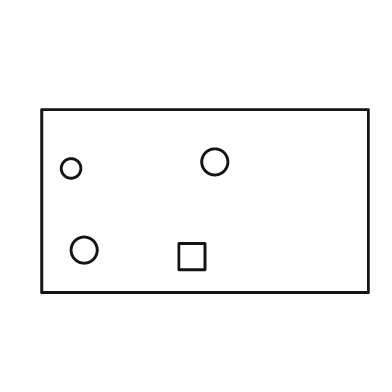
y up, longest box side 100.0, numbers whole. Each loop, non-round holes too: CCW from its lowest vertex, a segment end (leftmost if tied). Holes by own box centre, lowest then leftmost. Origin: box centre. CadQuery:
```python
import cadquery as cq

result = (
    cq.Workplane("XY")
    .moveTo(-50.0, -28.0)
    .lineTo(50.0, -28.0)
    .lineTo(50.0, 28.0)
    .lineTo(-50.0, 28.0)
    .close()
    .moveTo(-8.0, -21.0)
    .lineTo(0.0, -21.0)
    .lineTo(0.0, -13.0)
    .lineTo(-8.0, -13.0)
    .close()
    .moveTo(-37.0, -15.0)
    .circle(4.0)
    .moveTo(-41.0, 10.0)
    .circle(3.0)
    .moveTo(3.0, 12.0)
    .circle(4.0)
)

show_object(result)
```